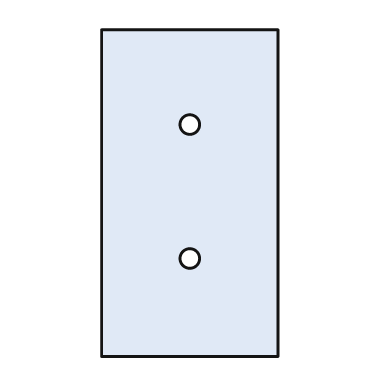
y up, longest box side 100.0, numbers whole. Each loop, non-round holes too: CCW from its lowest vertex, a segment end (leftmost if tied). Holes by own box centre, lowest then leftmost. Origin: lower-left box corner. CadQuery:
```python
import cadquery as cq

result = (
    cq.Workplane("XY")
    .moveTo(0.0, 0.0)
    .lineTo(54.0, 0.0)
    .lineTo(54.0, 100.0)
    .lineTo(0.0, 100.0)
    .close()
    .moveTo(27.0, 30.0)
    .circle(3.0)
    .moveTo(27.0, 71.0)
    .circle(3.0)
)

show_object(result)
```